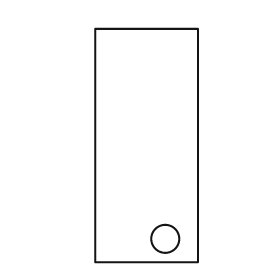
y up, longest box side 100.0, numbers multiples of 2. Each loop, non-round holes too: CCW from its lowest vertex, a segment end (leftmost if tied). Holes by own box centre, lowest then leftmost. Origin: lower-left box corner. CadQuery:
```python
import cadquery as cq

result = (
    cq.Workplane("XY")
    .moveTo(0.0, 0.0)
    .lineTo(44.0, 0.0)
    .lineTo(44.0, 100.0)
    .lineTo(0.0, 100.0)
    .close()
    .moveTo(30.0, 10.0)
    .circle(6.0)
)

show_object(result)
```